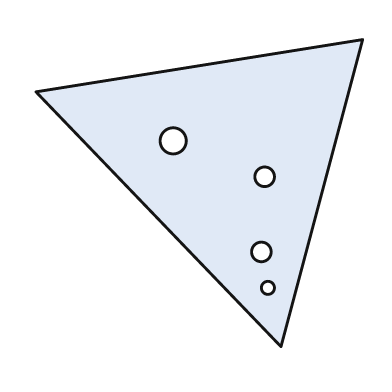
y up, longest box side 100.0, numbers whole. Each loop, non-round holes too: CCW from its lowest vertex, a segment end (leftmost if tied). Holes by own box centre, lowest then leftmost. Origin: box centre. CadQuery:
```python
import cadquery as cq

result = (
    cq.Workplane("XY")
    .moveTo(25.0, -47.0)
    .lineTo(50.0, 47.0)
    .lineTo(-50.0, 31.0)
    .close()
    .moveTo(21.0, -29.0)
    .circle(2.0)
    .moveTo(19.0, -18.0)
    .circle(3.0)
    .moveTo(20.0, 5.0)
    .circle(3.0)
    .moveTo(-8.0, 16.0)
    .circle(4.0)
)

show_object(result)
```